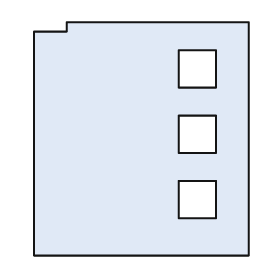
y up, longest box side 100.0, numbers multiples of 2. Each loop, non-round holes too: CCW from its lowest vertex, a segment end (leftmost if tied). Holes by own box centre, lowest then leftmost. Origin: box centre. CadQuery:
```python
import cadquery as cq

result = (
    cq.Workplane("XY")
    .moveTo(-46.0, -50.0)
    .lineTo(46.0, -50.0)
    .lineTo(46.0, 50.0)
    .lineTo(-32.0, 50.0)
    .lineTo(-32.0, 46.0)
    .lineTo(-46.0, 46.0)
    .close()
    .moveTo(16.0, -34.0)
    .lineTo(32.0, -34.0)
    .lineTo(32.0, -18.0)
    .lineTo(16.0, -18.0)
    .close()
    .moveTo(16.0, -6.0)
    .lineTo(32.0, -6.0)
    .lineTo(32.0, 10.0)
    .lineTo(16.0, 10.0)
    .close()
    .moveTo(16.0, 22.0)
    .lineTo(32.0, 22.0)
    .lineTo(32.0, 38.0)
    .lineTo(16.0, 38.0)
    .close()
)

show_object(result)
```